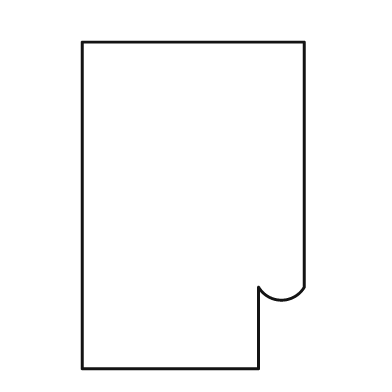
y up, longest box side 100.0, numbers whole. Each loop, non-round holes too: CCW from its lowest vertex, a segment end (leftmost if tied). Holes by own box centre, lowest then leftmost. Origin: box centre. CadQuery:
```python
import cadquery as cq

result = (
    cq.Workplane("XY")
    .moveTo(-34.0, -50.0)
    .lineTo(20.0, -50.0)
    .lineTo(20.0, -25.0)
    .threePointArc((27.0, -29.0), (34.0, -25.0))
    .lineTo(34.0, 50.0)
    .lineTo(-34.0, 50.0)
    .close()
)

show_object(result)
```